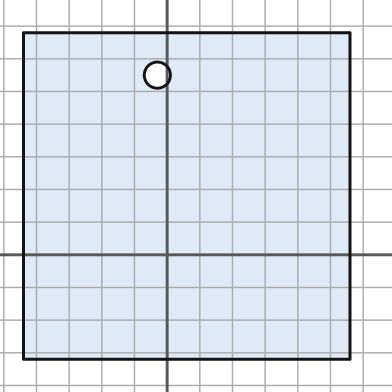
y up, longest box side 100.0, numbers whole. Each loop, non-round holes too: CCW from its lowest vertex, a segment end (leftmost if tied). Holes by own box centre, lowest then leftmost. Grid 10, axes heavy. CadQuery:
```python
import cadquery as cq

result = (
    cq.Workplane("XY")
    .moveTo(-44.0, -32.0)
    .lineTo(56.0, -32.0)
    .lineTo(56.0, 68.0)
    .lineTo(-44.0, 68.0)
    .close()
    .moveTo(-3.0, 55.0)
    .circle(4.0)
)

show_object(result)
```